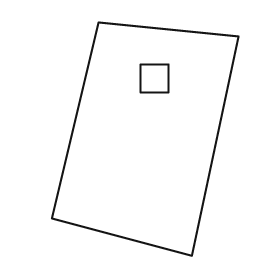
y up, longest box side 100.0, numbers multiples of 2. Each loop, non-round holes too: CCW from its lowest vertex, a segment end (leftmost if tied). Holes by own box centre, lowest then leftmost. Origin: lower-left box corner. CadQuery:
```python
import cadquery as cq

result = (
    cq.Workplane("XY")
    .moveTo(60.0, 0.0)
    .lineTo(80.0, 94.0)
    .lineTo(20.0, 100.0)
    .lineTo(0.0, 16.0)
    .close()
    .moveTo(38.0, 70.0)
    .lineTo(50.0, 70.0)
    .lineTo(50.0, 82.0)
    .lineTo(38.0, 82.0)
    .close()
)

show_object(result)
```